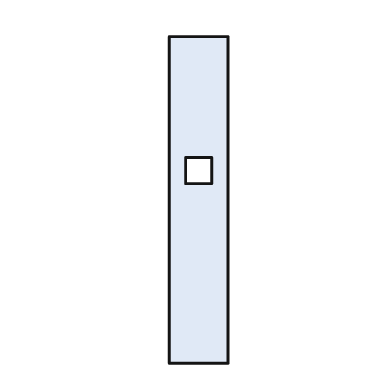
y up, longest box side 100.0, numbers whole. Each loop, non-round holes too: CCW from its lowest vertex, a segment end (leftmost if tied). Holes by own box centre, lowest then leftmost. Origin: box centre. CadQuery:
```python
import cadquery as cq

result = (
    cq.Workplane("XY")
    .moveTo(-9.0, -50.0)
    .lineTo(9.0, -50.0)
    .lineTo(9.0, 50.0)
    .lineTo(-9.0, 50.0)
    .close()
    .moveTo(-4.0, 5.0)
    .lineTo(4.0, 5.0)
    .lineTo(4.0, 13.0)
    .lineTo(-4.0, 13.0)
    .close()
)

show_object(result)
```